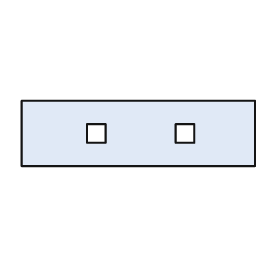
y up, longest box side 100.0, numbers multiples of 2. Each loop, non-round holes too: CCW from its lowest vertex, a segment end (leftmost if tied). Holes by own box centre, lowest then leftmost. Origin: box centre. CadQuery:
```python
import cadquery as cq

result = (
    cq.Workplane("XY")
    .moveTo(-50.0, -14.0)
    .lineTo(50.0, -14.0)
    .lineTo(50.0, 14.0)
    .lineTo(-50.0, 14.0)
    .close()
    .moveTo(-22.0, -4.0)
    .lineTo(-14.0, -4.0)
    .lineTo(-14.0, 4.0)
    .lineTo(-22.0, 4.0)
    .close()
    .moveTo(16.0, -4.0)
    .lineTo(24.0, -4.0)
    .lineTo(24.0, 4.0)
    .lineTo(16.0, 4.0)
    .close()
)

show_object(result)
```